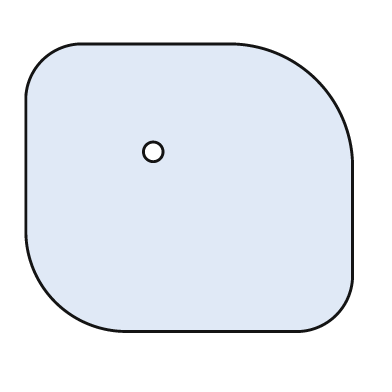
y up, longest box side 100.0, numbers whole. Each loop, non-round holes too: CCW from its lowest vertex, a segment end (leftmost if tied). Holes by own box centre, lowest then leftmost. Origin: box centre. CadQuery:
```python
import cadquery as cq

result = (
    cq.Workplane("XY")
    .moveTo(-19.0, -44.0)
    .lineTo(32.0, -44.0)
    .threePointArc((45.0, -39.0), (50.0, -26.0))
    .lineTo(50.0, 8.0)
    .threePointArc((39.0, 33.0), (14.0, 44.0))
    .lineTo(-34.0, 44.0)
    .threePointArc((-45.0, 39.0), (-50.0, 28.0))
    .lineTo(-50.0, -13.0)
    .threePointArc((-41.0, -35.0), (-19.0, -44.0))
    .close()
    .moveTo(-11.0, 11.0)
    .circle(3.0)
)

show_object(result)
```